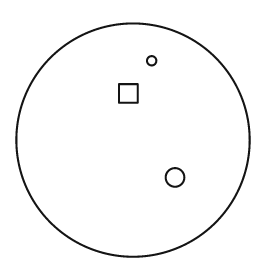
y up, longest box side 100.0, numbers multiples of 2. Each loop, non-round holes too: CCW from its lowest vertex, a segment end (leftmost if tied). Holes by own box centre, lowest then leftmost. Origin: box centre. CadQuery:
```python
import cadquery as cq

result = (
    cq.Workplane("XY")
    .moveTo(0.0, 0.0)
    .circle(50.0)
    .moveTo(18.0, -16.0)
    .circle(4.0)
    .moveTo(-6.0, 16.0)
    .lineTo(2.0, 16.0)
    .lineTo(2.0, 24.0)
    .lineTo(-6.0, 24.0)
    .close()
    .moveTo(8.0, 34.0)
    .circle(2.0)
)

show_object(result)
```